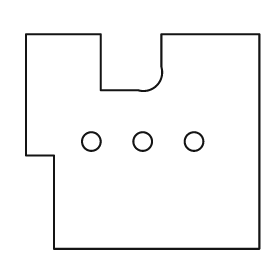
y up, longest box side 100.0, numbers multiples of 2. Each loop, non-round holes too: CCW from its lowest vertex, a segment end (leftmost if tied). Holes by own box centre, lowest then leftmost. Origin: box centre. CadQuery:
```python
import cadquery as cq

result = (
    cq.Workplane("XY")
    .moveTo(-38.0, -46.0)
    .lineTo(50.0, -46.0)
    .lineTo(50.0, 46.0)
    .lineTo(8.0, 46.0)
    .lineTo(8.0, 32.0)
    .threePointArc((6.0, 24.0), (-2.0, 22.0))
    .lineTo(-18.0, 22.0)
    .lineTo(-18.0, 46.0)
    .lineTo(-50.0, 46.0)
    .lineTo(-50.0, -6.0)
    .lineTo(-38.0, -6.0)
    .close()
    .moveTo(-22.0, 0.0)
    .circle(4.0)
    .moveTo(0.0, 0.0)
    .circle(4.0)
    .moveTo(22.0, 0.0)
    .circle(4.0)
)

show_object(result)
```